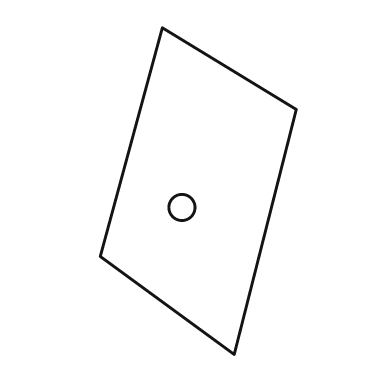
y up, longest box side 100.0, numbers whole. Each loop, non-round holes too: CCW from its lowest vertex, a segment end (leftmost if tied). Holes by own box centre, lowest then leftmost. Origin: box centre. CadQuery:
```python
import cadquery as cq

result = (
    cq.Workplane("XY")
    .moveTo(11.0, -50.0)
    .lineTo(30.0, 25.0)
    .lineTo(-11.0, 50.0)
    .lineTo(-30.0, -20.0)
    .close()
    .moveTo(-5.0, -5.0)
    .circle(4.0)
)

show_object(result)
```